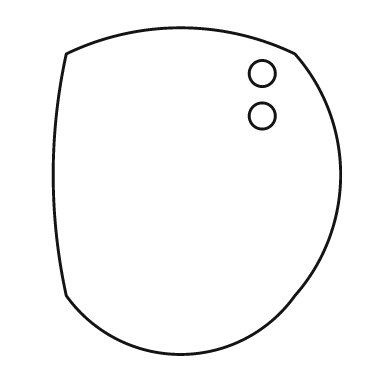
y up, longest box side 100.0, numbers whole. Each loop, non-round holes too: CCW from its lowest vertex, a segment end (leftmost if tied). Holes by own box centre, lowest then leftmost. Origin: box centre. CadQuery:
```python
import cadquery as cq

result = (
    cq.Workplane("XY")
    .moveTo(-40.0, -32.0)
    .threePointArc((-5.0, -50.0), (30.0, -32.0))
    .threePointArc((44.0, 5.0), (30.0, 42.0))
    .threePointArc((-5.0, 50.0), (-40.0, 42.0))
    .threePointArc((-44.0, 5.0), (-40.0, -32.0))
    .close()
    .moveTo(20.0, 23.0)
    .circle(4.0)
    .moveTo(20.0, 36.0)
    .circle(4.0)
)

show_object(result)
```